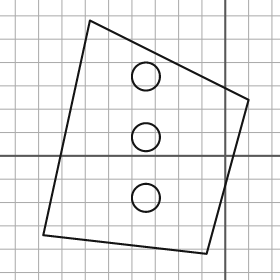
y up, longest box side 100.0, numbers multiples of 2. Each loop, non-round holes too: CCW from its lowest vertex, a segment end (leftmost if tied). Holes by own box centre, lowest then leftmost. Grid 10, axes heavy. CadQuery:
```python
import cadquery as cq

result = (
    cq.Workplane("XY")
    .moveTo(-8.0, -42.0)
    .lineTo(10.0, 24.0)
    .lineTo(-58.0, 58.0)
    .lineTo(-78.0, -34.0)
    .close()
    .moveTo(-34.0, -18.0)
    .circle(6.0)
    .moveTo(-34.0, 8.0)
    .circle(6.0)
    .moveTo(-34.0, 34.0)
    .circle(6.0)
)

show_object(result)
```